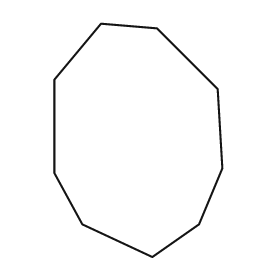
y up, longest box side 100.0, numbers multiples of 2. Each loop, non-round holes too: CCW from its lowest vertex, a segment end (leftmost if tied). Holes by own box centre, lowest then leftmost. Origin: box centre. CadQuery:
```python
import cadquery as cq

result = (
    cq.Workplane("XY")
    .moveTo(6.0, -50.0)
    .lineTo(26.0, -36.0)
    .lineTo(36.0, -12.0)
    .lineTo(34.0, 22.0)
    .lineTo(8.0, 48.0)
    .lineTo(-16.0, 50.0)
    .lineTo(-36.0, 26.0)
    .lineTo(-36.0, -14.0)
    .lineTo(-24.0, -36.0)
    .close()
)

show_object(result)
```